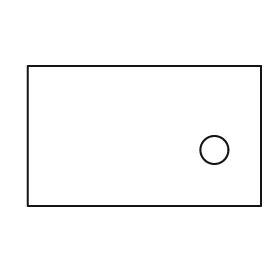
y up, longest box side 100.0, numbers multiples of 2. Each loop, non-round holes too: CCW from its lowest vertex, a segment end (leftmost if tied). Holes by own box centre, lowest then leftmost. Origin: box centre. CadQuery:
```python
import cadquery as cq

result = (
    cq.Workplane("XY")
    .moveTo(-50.0, -30.0)
    .lineTo(50.0, -30.0)
    .lineTo(50.0, 30.0)
    .lineTo(-50.0, 30.0)
    .close()
    .moveTo(30.0, -6.0)
    .circle(6.0)
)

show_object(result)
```